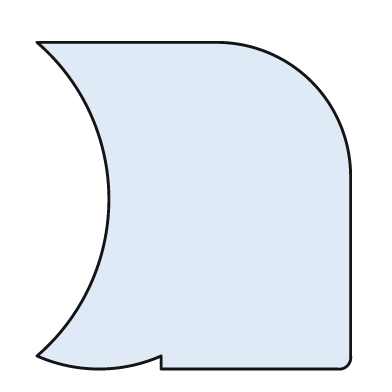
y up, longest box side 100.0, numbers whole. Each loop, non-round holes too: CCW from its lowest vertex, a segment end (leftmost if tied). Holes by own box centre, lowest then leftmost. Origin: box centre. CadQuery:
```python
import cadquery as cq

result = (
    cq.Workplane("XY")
    .moveTo(-10.0, -50.0)
    .lineTo(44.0, -50.0)
    .threePointArc((47.0, -49.0), (48.0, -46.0))
    .lineTo(48.0, 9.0)
    .threePointArc((36.0, 38.0), (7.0, 50.0))
    .lineTo(-48.0, 50.0)
    .threePointArc((-26.0, 2.0), (-48.0, -46.0))
    .threePointArc((-29.0, -50.0), (-10.0, -46.0))
    .close()
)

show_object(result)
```